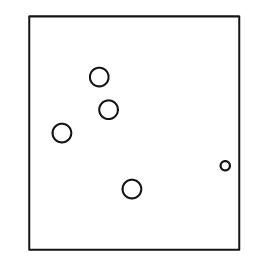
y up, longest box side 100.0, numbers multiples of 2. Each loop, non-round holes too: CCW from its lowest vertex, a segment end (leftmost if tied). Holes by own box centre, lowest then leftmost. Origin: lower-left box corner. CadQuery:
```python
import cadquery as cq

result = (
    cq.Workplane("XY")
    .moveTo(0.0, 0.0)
    .lineTo(90.0, 0.0)
    .lineTo(90.0, 100.0)
    .lineTo(0.0, 100.0)
    .close()
    .moveTo(44.0, 26.0)
    .circle(4.0)
    .moveTo(84.0, 36.0)
    .circle(2.0)
    .moveTo(14.0, 50.0)
    .circle(4.0)
    .moveTo(34.0, 60.0)
    .circle(4.0)
    .moveTo(30.0, 74.0)
    .circle(4.0)
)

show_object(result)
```